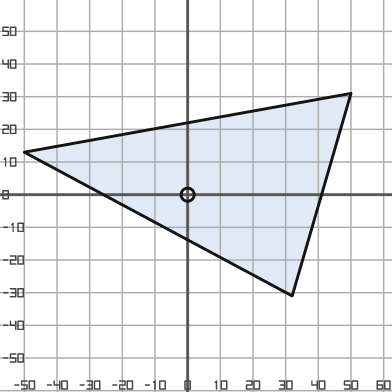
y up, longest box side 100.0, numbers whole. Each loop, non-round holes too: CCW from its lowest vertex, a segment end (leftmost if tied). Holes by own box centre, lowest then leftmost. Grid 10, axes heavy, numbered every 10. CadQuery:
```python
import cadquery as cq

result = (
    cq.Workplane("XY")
    .moveTo(32.0, -31.0)
    .lineTo(50.0, 31.0)
    .lineTo(-50.0, 13.0)
    .close()
    .moveTo(0.0, 0.0)
    .circle(2.0)
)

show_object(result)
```